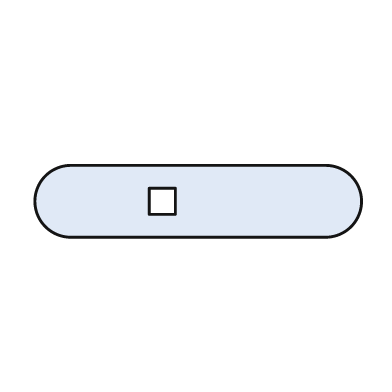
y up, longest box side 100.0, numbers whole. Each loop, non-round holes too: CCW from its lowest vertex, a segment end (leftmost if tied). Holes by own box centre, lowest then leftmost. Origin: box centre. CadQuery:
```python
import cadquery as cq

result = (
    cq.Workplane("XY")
    .moveTo(-39.0, -11.0)
    .lineTo(39.0, -11.0)
    .threePointArc((50.0, 0.0), (39.0, 11.0))
    .lineTo(-39.0, 11.0)
    .threePointArc((-50.0, 0.0), (-39.0, -11.0))
    .close()
    .moveTo(-15.0, -4.0)
    .lineTo(-7.0, -4.0)
    .lineTo(-7.0, 4.0)
    .lineTo(-15.0, 4.0)
    .close()
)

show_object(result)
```